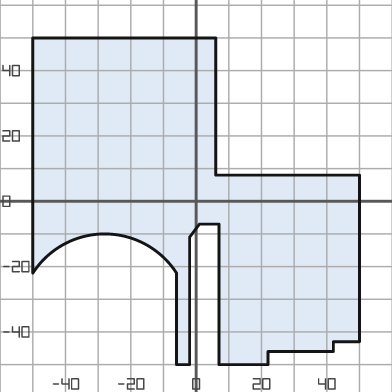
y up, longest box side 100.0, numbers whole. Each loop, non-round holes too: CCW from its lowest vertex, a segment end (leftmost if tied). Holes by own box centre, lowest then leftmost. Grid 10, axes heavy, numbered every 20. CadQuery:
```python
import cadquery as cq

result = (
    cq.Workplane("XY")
    .moveTo(-6.0, -50.0)
    .lineTo(-2.0, -50.0)
    .lineTo(-2.0, -11.0)
    .lineTo(1.0, -7.0)
    .lineTo(7.0, -7.0)
    .lineTo(7.0, -50.0)
    .lineTo(22.0, -50.0)
    .lineTo(22.0, -46.0)
    .lineTo(42.0, -46.0)
    .lineTo(42.0, -43.0)
    .lineTo(50.0, -43.0)
    .lineTo(50.0, 8.0)
    .lineTo(6.0, 8.0)
    .lineTo(6.0, 50.0)
    .lineTo(-50.0, 50.0)
    .lineTo(-50.0, -22.0)
    .threePointArc((-28.0, -10.0), (-6.0, -22.0))
    .close()
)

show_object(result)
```